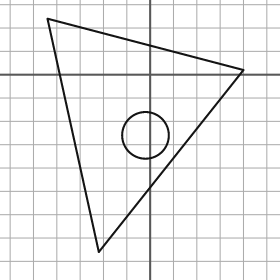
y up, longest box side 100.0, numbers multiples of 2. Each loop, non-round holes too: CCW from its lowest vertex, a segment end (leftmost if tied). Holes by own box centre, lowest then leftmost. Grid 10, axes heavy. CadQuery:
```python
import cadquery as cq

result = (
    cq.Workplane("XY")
    .moveTo(-22.0, -76.0)
    .lineTo(40.0, 2.0)
    .lineTo(-44.0, 24.0)
    .close()
    .moveTo(-2.0, -26.0)
    .circle(10.0)
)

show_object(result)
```